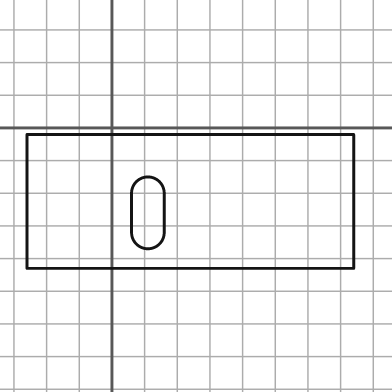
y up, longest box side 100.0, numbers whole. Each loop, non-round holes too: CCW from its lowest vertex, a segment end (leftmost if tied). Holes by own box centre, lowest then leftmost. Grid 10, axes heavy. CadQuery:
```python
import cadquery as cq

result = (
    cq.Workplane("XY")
    .moveTo(-26.0, -43.0)
    .lineTo(74.0, -43.0)
    .lineTo(74.0, -2.0)
    .lineTo(-26.0, -2.0)
    .close()
    .moveTo(6.0, -32.0)
    .threePointArc((11.0, -37.0), (16.0, -32.0))
    .lineTo(16.0, -20.0)
    .threePointArc((11.0, -15.0), (6.0, -20.0))
    .close()
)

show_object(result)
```